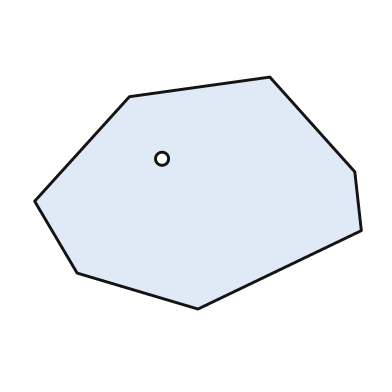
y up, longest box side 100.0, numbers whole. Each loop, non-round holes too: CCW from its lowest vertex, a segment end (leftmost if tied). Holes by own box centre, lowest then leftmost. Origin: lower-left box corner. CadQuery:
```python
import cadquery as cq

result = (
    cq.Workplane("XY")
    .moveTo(50.0, 0.0)
    .lineTo(100.0, 24.0)
    .lineTo(98.0, 42.0)
    .lineTo(72.0, 71.0)
    .lineTo(29.0, 65.0)
    .lineTo(0.0, 33.0)
    .lineTo(13.0, 11.0)
    .close()
    .moveTo(39.0, 46.0)
    .circle(2.0)
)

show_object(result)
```